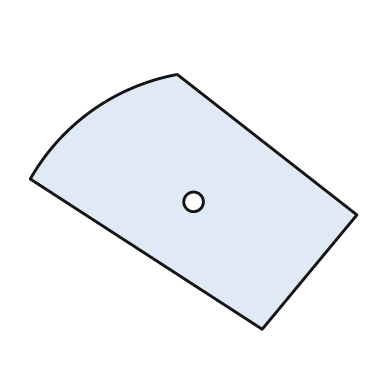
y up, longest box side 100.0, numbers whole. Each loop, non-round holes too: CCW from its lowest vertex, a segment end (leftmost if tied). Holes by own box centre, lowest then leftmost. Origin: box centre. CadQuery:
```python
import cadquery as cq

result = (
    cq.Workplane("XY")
    .moveTo(21.0, -39.0)
    .lineTo(50.0, -4.0)
    .lineTo(-5.0, 39.0)
    .threePointArc((-31.0, 28.0), (-50.0, 7.0))
    .close()
    .moveTo(0.0, 0.0)
    .circle(3.0)
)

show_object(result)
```